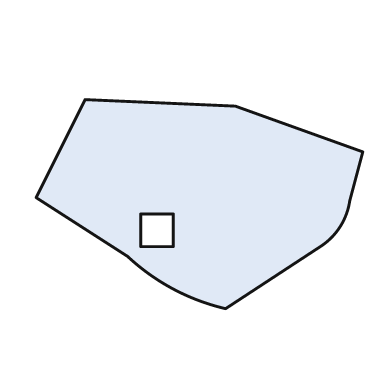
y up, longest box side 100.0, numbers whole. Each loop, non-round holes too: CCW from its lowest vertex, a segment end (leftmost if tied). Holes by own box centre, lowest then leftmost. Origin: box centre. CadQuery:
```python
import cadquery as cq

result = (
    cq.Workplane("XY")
    .moveTo(8.0, -32.0)
    .lineTo(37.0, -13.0)
    .threePointArc((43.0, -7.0), (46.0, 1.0))
    .lineTo(50.0, 16.0)
    .lineTo(11.0, 30.0)
    .lineTo(-35.0, 32.0)
    .lineTo(-50.0, 2.0)
    .lineTo(-22.0, -16.0)
    .threePointArc((-8.0, -26.0), (8.0, -32.0))
    .close()
    .moveTo(-18.0, -13.0)
    .lineTo(-8.0, -13.0)
    .lineTo(-8.0, -3.0)
    .lineTo(-18.0, -3.0)
    .close()
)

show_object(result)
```